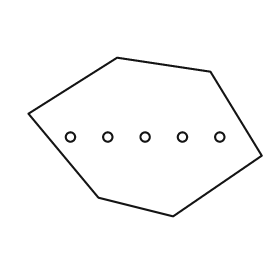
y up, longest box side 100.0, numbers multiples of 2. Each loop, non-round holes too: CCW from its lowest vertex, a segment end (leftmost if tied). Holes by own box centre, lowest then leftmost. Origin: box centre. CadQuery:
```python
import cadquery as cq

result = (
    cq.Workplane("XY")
    .moveTo(12.0, -34.0)
    .lineTo(50.0, -8.0)
    .lineTo(28.0, 28.0)
    .lineTo(-12.0, 34.0)
    .lineTo(-50.0, 10.0)
    .lineTo(-20.0, -26.0)
    .close()
    .moveTo(-32.0, 0.0)
    .circle(2.0)
    .moveTo(-16.0, 0.0)
    .circle(2.0)
    .moveTo(0.0, 0.0)
    .circle(2.0)
    .moveTo(16.0, 0.0)
    .circle(2.0)
    .moveTo(32.0, 0.0)
    .circle(2.0)
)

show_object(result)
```